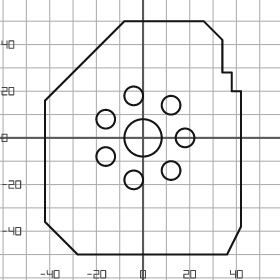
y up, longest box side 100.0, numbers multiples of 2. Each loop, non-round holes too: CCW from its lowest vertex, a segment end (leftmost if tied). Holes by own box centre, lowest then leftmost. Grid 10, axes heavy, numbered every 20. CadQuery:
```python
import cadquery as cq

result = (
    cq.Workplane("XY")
    .moveTo(-28.0, -50.0)
    .lineTo(36.0, -50.0)
    .lineTo(42.0, -38.0)
    .lineTo(42.0, 20.0)
    .lineTo(38.0, 20.0)
    .lineTo(38.0, 28.0)
    .lineTo(34.0, 28.0)
    .lineTo(34.0, 42.0)
    .lineTo(26.0, 50.0)
    .lineTo(-8.0, 50.0)
    .lineTo(-42.0, 16.0)
    .lineTo(-42.0, -36.0)
    .close()
    .moveTo(-4.0, -18.0)
    .circle(4.0)
    .moveTo(12.0, -14.0)
    .circle(4.0)
    .moveTo(-16.0, -8.0)
    .circle(4.0)
    .moveTo(0.0, 0.0)
    .circle(8.0)
    .moveTo(18.0, 0.0)
    .circle(4.0)
    .moveTo(-16.0, 8.0)
    .circle(4.0)
    .moveTo(12.0, 14.0)
    .circle(4.0)
    .moveTo(-4.0, 18.0)
    .circle(4.0)
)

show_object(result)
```